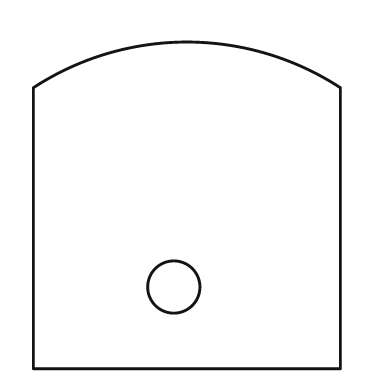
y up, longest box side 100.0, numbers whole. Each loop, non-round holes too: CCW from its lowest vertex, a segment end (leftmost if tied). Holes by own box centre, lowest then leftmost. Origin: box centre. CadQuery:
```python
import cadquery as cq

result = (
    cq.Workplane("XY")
    .moveTo(-47.0, -50.0)
    .lineTo(47.0, -50.0)
    .lineTo(47.0, 36.0)
    .threePointArc((0.0, 50.0), (-47.0, 36.0))
    .close()
    .moveTo(-4.0, -25.0)
    .circle(8.0)
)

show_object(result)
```